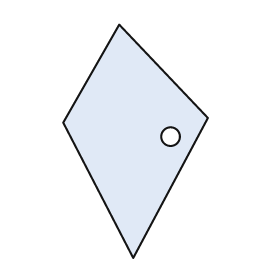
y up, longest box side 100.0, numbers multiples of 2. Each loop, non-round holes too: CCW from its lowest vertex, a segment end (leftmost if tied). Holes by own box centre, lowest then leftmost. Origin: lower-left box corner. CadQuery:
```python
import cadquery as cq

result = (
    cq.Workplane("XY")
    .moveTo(30.0, 0.0)
    .lineTo(62.0, 60.0)
    .lineTo(24.0, 100.0)
    .lineTo(0.0, 58.0)
    .close()
    .moveTo(46.0, 52.0)
    .circle(4.0)
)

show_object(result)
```